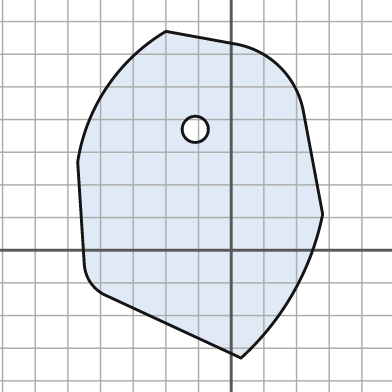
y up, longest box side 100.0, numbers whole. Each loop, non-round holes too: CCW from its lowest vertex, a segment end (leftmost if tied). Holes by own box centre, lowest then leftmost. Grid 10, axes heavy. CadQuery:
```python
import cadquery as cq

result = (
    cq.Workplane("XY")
    .moveTo(3.0, -33.0)
    .threePointArc((19.0, -13.0), (28.0, 11.0))
    .lineTo(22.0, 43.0)
    .threePointArc((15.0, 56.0), (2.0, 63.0))
    .lineTo(-20.0, 67.0)
    .threePointArc((-38.0, 50.0), (-47.0, 27.0))
    .lineTo(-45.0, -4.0)
    .threePointArc((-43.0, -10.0), (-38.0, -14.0))
    .close()
    .moveTo(-11.0, 37.0)
    .circle(4.0)
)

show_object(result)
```